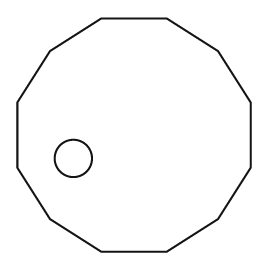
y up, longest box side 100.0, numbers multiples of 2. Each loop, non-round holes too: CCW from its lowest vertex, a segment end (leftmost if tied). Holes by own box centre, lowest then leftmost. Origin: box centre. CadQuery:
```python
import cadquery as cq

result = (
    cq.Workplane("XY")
    .moveTo(-14.0, -50.0)
    .lineTo(14.0, -50.0)
    .lineTo(36.0, -36.0)
    .lineTo(50.0, -14.0)
    .lineTo(50.0, 14.0)
    .lineTo(36.0, 36.0)
    .lineTo(14.0, 50.0)
    .lineTo(-14.0, 50.0)
    .lineTo(-36.0, 36.0)
    .lineTo(-50.0, 14.0)
    .lineTo(-50.0, -14.0)
    .lineTo(-36.0, -36.0)
    .close()
    .moveTo(-26.0, -10.0)
    .circle(8.0)
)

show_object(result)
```